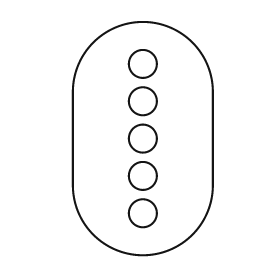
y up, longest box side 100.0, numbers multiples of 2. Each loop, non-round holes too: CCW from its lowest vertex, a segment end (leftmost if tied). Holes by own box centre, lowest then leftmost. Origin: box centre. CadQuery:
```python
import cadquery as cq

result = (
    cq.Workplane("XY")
    .moveTo(-30.0, -20.0)
    .threePointArc((0.0, -50.0), (30.0, -20.0))
    .lineTo(30.0, 20.0)
    .threePointArc((0.0, 50.0), (-30.0, 20.0))
    .close()
    .moveTo(0.0, -32.0)
    .circle(6.0)
    .moveTo(0.0, -16.0)
    .circle(6.0)
    .moveTo(0.0, 0.0)
    .circle(6.0)
    .moveTo(0.0, 16.0)
    .circle(6.0)
    .moveTo(0.0, 32.0)
    .circle(6.0)
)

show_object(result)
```